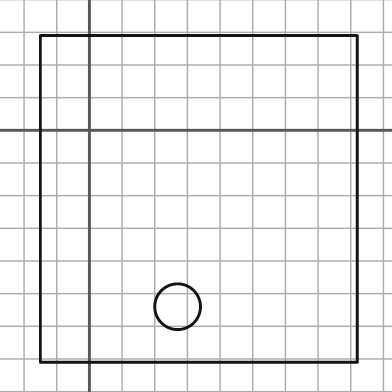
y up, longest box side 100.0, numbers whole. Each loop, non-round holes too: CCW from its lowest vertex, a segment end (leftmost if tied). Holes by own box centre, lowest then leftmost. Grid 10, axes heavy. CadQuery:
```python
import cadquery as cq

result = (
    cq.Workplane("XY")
    .moveTo(-15.0, -71.0)
    .lineTo(82.0, -71.0)
    .lineTo(82.0, 29.0)
    .lineTo(-15.0, 29.0)
    .close()
    .moveTo(27.0, -54.0)
    .circle(7.0)
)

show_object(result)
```